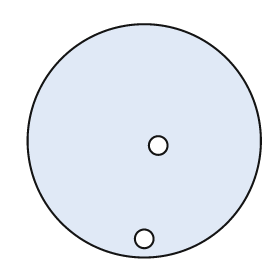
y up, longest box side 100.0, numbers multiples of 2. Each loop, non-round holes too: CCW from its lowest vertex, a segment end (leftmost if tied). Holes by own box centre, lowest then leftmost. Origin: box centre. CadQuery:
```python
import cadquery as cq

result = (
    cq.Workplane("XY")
    .moveTo(0.0, 0.0)
    .circle(50.0)
    .moveTo(0.0, -42.0)
    .circle(4.0)
    .moveTo(6.0, -2.0)
    .circle(4.0)
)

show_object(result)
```